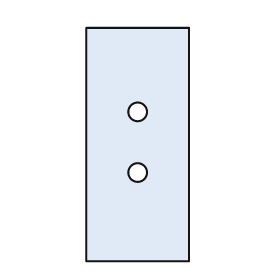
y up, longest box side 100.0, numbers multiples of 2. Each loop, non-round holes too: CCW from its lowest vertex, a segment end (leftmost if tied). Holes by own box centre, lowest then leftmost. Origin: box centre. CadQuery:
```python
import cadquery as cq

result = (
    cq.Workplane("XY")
    .moveTo(-22.0, -50.0)
    .lineTo(22.0, -50.0)
    .lineTo(22.0, 50.0)
    .lineTo(-22.0, 50.0)
    .close()
    .moveTo(0.0, -12.0)
    .circle(4.0)
    .moveTo(0.0, 14.0)
    .circle(4.0)
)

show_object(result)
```